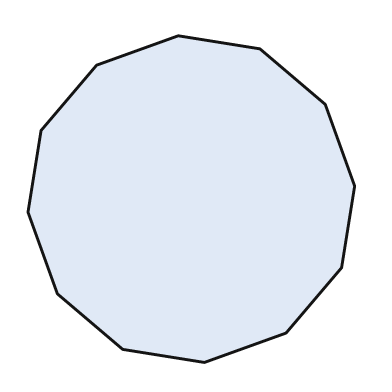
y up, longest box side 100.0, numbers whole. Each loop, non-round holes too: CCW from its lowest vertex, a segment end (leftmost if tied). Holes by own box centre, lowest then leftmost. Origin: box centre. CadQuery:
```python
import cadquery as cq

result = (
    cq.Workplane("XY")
    .moveTo(4.0, -50.0)
    .lineTo(29.0, -41.0)
    .lineTo(46.0, -21.0)
    .lineTo(50.0, 4.0)
    .lineTo(41.0, 29.0)
    .lineTo(21.0, 46.0)
    .lineTo(-4.0, 50.0)
    .lineTo(-29.0, 41.0)
    .lineTo(-46.0, 21.0)
    .lineTo(-50.0, -4.0)
    .lineTo(-41.0, -29.0)
    .lineTo(-21.0, -46.0)
    .close()
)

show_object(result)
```